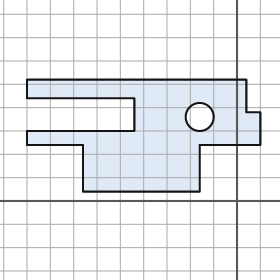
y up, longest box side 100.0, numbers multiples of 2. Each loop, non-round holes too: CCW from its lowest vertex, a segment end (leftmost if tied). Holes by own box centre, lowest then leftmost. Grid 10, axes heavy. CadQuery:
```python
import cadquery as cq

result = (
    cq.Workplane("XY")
    .moveTo(-66.0, 4.0)
    .lineTo(-16.0, 4.0)
    .lineTo(-16.0, 24.0)
    .lineTo(10.0, 24.0)
    .lineTo(10.0, 38.0)
    .lineTo(4.0, 38.0)
    .lineTo(4.0, 52.0)
    .lineTo(-90.0, 52.0)
    .lineTo(-90.0, 44.0)
    .lineTo(-44.0, 44.0)
    .lineTo(-44.0, 30.0)
    .lineTo(-90.0, 30.0)
    .lineTo(-90.0, 24.0)
    .lineTo(-66.0, 24.0)
    .close()
    .moveTo(-16.0, 36.0)
    .circle(6.0)
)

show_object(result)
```